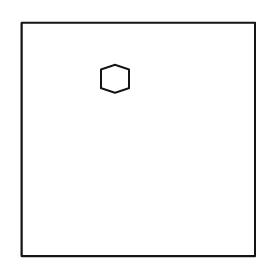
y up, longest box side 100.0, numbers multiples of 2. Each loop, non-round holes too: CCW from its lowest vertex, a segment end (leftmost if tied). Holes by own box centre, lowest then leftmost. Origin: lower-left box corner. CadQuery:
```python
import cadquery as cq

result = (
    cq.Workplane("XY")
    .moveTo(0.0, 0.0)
    .lineTo(100.0, 0.0)
    .lineTo(100.0, 100.0)
    .lineTo(0.0, 100.0)
    .close()
    .moveTo(40.0, 70.0)
    .lineTo(46.0, 72.0)
    .lineTo(46.0, 80.0)
    .lineTo(40.0, 82.0)
    .lineTo(34.0, 80.0)
    .lineTo(34.0, 72.0)
    .close()
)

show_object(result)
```